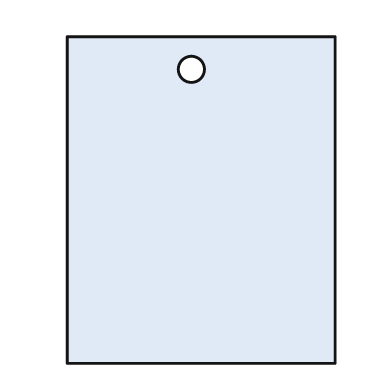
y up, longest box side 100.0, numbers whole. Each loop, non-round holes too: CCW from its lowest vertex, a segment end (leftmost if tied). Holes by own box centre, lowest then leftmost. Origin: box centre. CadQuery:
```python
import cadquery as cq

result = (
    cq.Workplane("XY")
    .moveTo(-41.0, -50.0)
    .lineTo(41.0, -50.0)
    .lineTo(41.0, 50.0)
    .lineTo(-41.0, 50.0)
    .close()
    .moveTo(-3.0, 40.0)
    .circle(4.0)
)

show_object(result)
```